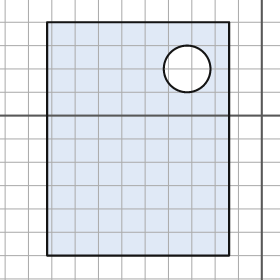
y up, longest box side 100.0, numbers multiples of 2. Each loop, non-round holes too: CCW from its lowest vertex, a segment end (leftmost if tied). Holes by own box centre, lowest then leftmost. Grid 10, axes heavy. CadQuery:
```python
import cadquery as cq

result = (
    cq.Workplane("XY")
    .moveTo(-92.0, -60.0)
    .lineTo(-14.0, -60.0)
    .lineTo(-14.0, 40.0)
    .lineTo(-92.0, 40.0)
    .close()
    .moveTo(-32.0, 20.0)
    .circle(10.0)
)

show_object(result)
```